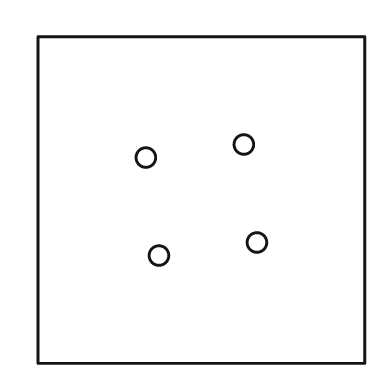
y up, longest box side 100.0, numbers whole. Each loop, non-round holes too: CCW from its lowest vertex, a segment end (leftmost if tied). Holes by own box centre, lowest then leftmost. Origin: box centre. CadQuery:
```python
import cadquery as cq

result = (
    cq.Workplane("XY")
    .moveTo(-50.0, -50.0)
    .lineTo(50.0, -50.0)
    .lineTo(50.0, 50.0)
    .lineTo(-50.0, 50.0)
    .close()
    .moveTo(-13.0, -17.0)
    .circle(3.0)
    .moveTo(17.0, -13.0)
    .circle(3.0)
    .moveTo(-17.0, 13.0)
    .circle(3.0)
    .moveTo(13.0, 17.0)
    .circle(3.0)
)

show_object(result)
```